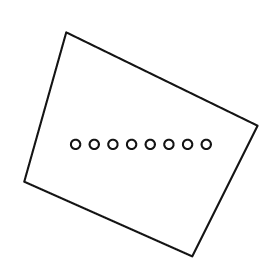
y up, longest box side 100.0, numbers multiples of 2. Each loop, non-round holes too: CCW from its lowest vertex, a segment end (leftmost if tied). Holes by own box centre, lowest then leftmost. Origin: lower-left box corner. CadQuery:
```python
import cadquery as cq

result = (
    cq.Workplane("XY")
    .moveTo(72.0, 0.0)
    .lineTo(100.0, 56.0)
    .lineTo(18.0, 96.0)
    .lineTo(0.0, 32.0)
    .close()
    .moveTo(22.0, 48.0)
    .circle(2.0)
    .moveTo(30.0, 48.0)
    .circle(2.0)
    .moveTo(38.0, 48.0)
    .circle(2.0)
    .moveTo(46.0, 48.0)
    .circle(2.0)
    .moveTo(54.0, 48.0)
    .circle(2.0)
    .moveTo(62.0, 48.0)
    .circle(2.0)
    .moveTo(70.0, 48.0)
    .circle(2.0)
    .moveTo(78.0, 48.0)
    .circle(2.0)
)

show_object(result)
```